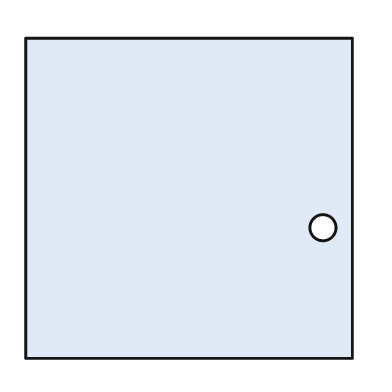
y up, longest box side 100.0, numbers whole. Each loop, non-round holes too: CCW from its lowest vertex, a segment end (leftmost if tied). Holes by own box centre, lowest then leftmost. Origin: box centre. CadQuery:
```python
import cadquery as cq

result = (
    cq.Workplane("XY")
    .moveTo(-50.0, -49.0)
    .lineTo(50.0, -49.0)
    .lineTo(50.0, 49.0)
    .lineTo(-50.0, 49.0)
    .close()
    .moveTo(41.0, -9.0)
    .circle(4.0)
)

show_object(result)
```